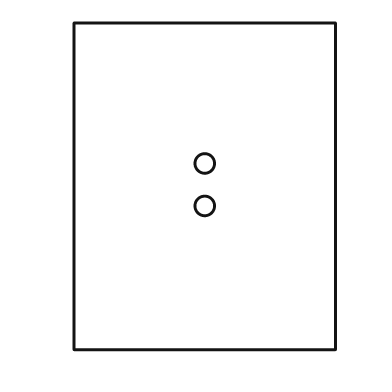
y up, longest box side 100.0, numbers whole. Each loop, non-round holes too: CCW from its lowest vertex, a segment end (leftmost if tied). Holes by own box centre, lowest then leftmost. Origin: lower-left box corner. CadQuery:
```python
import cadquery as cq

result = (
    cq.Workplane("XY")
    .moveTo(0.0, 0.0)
    .lineTo(80.0, 0.0)
    .lineTo(80.0, 100.0)
    .lineTo(0.0, 100.0)
    .close()
    .moveTo(40.0, 44.0)
    .circle(3.0)
    .moveTo(40.0, 57.0)
    .circle(3.0)
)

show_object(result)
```